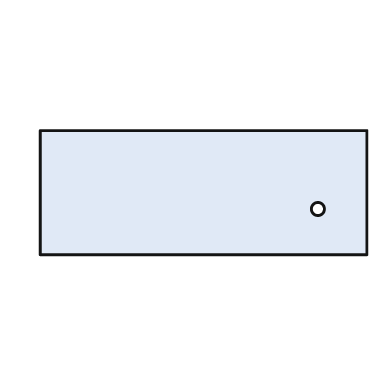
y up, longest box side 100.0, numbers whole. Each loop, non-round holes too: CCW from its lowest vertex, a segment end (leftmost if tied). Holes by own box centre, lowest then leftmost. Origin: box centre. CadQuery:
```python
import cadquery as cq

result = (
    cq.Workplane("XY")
    .moveTo(-50.0, -19.0)
    .lineTo(50.0, -19.0)
    .lineTo(50.0, 19.0)
    .lineTo(-50.0, 19.0)
    .close()
    .moveTo(35.0, -5.0)
    .circle(2.0)
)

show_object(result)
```